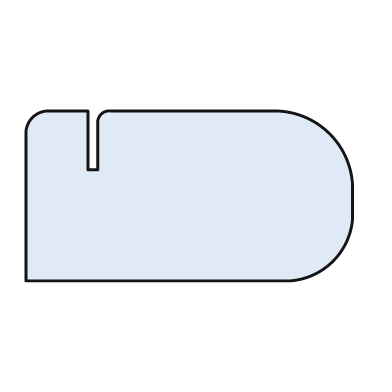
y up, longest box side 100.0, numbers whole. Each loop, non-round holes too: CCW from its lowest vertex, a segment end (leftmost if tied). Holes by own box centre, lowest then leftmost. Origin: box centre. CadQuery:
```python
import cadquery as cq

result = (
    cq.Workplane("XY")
    .moveTo(-50.0, -26.0)
    .lineTo(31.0, -26.0)
    .threePointArc((44.0, -20.0), (50.0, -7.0))
    .lineTo(50.0, 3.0)
    .threePointArc((43.0, 19.0), (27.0, 26.0))
    .lineTo(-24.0, 26.0)
    .threePointArc((-27.0, 25.0), (-28.0, 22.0))
    .lineTo(-28.0, 8.0)
    .lineTo(-31.0, 8.0)
    .lineTo(-31.0, 26.0)
    .lineTo(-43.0, 26.0)
    .threePointArc((-48.0, 24.0), (-50.0, 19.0))
    .close()
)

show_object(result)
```